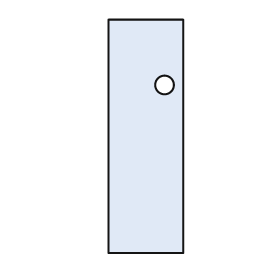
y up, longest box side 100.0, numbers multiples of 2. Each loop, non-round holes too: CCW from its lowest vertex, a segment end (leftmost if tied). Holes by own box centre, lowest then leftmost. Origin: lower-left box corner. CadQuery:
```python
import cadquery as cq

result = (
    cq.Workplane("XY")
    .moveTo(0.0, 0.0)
    .lineTo(32.0, 0.0)
    .lineTo(32.0, 100.0)
    .lineTo(0.0, 100.0)
    .close()
    .moveTo(24.0, 72.0)
    .circle(4.0)
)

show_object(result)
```